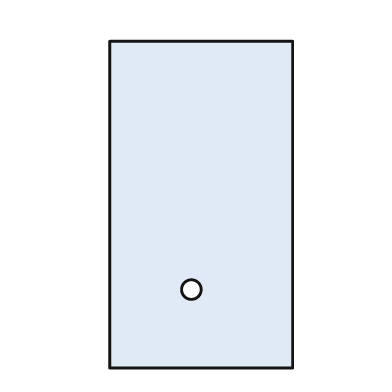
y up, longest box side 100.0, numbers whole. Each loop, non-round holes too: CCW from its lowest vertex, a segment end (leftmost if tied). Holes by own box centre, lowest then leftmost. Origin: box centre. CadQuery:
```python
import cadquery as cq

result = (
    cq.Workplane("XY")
    .moveTo(-28.0, -50.0)
    .lineTo(28.0, -50.0)
    .lineTo(28.0, 50.0)
    .lineTo(-28.0, 50.0)
    .close()
    .moveTo(-3.0, -26.0)
    .circle(3.0)
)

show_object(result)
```